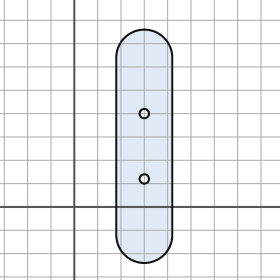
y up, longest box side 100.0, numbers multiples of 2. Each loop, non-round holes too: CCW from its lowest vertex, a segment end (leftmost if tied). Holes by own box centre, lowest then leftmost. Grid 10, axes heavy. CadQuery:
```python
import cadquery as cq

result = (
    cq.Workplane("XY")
    .moveTo(18.0, -12.0)
    .threePointArc((30.0, -24.0), (42.0, -12.0))
    .lineTo(42.0, 64.0)
    .threePointArc((30.0, 76.0), (18.0, 64.0))
    .close()
    .moveTo(30.0, 12.0)
    .circle(2.0)
    .moveTo(30.0, 40.0)
    .circle(2.0)
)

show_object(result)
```